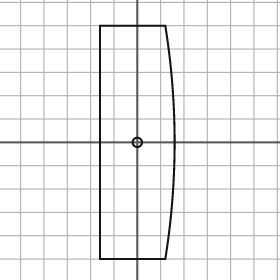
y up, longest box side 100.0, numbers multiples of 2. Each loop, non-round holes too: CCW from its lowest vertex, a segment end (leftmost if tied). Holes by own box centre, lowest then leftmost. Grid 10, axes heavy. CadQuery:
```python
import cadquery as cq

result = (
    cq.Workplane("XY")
    .moveTo(-16.0, -50.0)
    .lineTo(12.0, -50.0)
    .threePointArc((16.0, 0.0), (12.0, 50.0))
    .lineTo(-16.0, 50.0)
    .close()
    .moveTo(0.0, 0.0)
    .circle(2.0)
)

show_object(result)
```